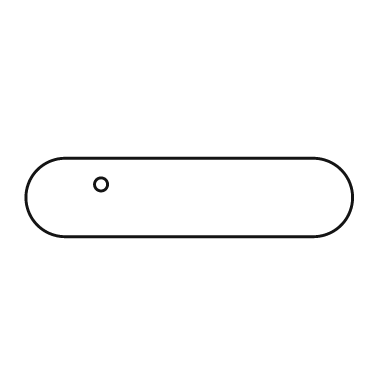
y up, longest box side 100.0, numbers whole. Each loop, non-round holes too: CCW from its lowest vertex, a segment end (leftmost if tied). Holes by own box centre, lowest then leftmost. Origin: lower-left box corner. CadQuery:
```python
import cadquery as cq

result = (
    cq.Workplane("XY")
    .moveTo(12.0, 0.0)
    .lineTo(88.0, 0.0)
    .threePointArc((100.0, 12.0), (88.0, 24.0))
    .lineTo(12.0, 24.0)
    .threePointArc((0.0, 12.0), (12.0, 0.0))
    .close()
    .moveTo(23.0, 16.0)
    .circle(2.0)
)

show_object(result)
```